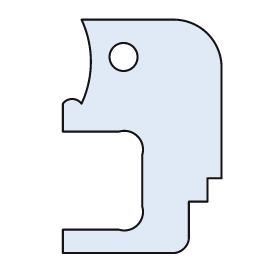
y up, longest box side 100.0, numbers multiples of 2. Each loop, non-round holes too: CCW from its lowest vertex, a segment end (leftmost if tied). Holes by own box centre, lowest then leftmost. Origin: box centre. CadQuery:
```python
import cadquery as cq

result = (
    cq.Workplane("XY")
    .moveTo(-34.0, -50.0)
    .lineTo(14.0, -50.0)
    .threePointArc((18.0, -48.0), (20.0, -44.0))
    .lineTo(20.0, -28.0)
    .lineTo(28.0, -28.0)
    .lineTo(28.0, -18.0)
    .lineTo(34.0, -18.0)
    .lineTo(34.0, 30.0)
    .threePointArc((28.0, 44.0), (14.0, 50.0))
    .lineTo(-26.0, 50.0)
    .threePointArc((-22.0, 32.0), (-26.0, 14.0))
    .threePointArc((-30.0, 16.0), (-34.0, 14.0))
    .lineTo(-34.0, 2.0)
    .lineTo(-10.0, 2.0)
    .threePointArc((-2.0, 0.0), (0.0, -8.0))
    .lineTo(0.0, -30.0)
    .threePointArc((-2.0, -38.0), (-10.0, -40.0))
    .lineTo(-34.0, -40.0)
    .close()
    .moveTo(-8.0, 34.0)
    .circle(6.0)
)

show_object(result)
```